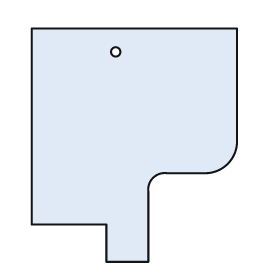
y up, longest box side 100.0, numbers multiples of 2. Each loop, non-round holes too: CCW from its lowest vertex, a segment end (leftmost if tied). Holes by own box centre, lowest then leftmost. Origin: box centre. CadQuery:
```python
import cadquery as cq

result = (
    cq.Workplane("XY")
    .moveTo(-12.0, -50.0)
    .lineTo(6.0, -50.0)
    .lineTo(6.0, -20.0)
    .threePointArc((8.0, -14.0), (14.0, -12.0))
    .lineTo(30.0, -12.0)
    .threePointArc((40.0, -8.0), (44.0, 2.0))
    .lineTo(44.0, 50.0)
    .lineTo(-44.0, 50.0)
    .lineTo(-44.0, -34.0)
    .lineTo(-12.0, -34.0)
    .close()
    .moveTo(-8.0, 40.0)
    .circle(2.0)
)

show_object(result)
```